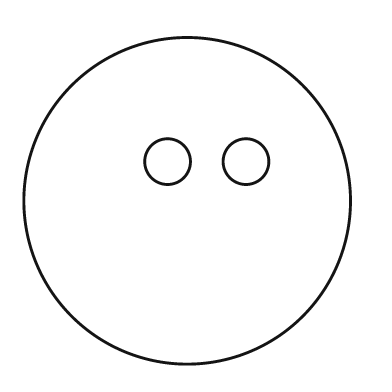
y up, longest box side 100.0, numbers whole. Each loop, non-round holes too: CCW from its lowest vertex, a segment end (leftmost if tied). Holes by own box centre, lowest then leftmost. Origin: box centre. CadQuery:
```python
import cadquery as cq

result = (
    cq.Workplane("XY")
    .moveTo(0.0, 0.0)
    .circle(50.0)
    .moveTo(-6.0, 12.0)
    .circle(7.0)
    .moveTo(18.0, 12.0)
    .circle(7.0)
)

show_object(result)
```